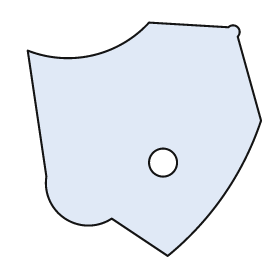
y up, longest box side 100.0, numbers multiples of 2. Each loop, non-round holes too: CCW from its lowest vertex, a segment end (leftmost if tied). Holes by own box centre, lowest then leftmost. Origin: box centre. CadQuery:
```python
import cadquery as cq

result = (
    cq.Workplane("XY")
    .moveTo(10.0, -50.0)
    .threePointArc((34.0, -24.0), (50.0, 8.0))
    .lineTo(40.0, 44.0)
    .threePointArc((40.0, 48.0), (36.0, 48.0))
    .lineTo(2.0, 50.0)
    .threePointArc((-22.0, 36.0), (-50.0, 38.0))
    .lineTo(-42.0, -16.0)
    .threePointArc((-34.0, -34.0), (-14.0, -34.0))
    .close()
    .moveTo(8.0, -10.0)
    .circle(6.0)
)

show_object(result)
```